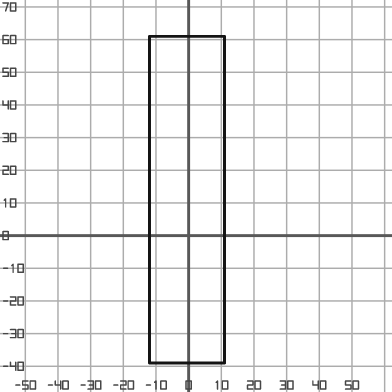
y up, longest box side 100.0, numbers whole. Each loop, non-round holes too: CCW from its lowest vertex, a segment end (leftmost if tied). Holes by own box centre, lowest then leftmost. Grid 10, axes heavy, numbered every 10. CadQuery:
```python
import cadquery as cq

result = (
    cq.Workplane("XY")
    .moveTo(-12.0, -39.0)
    .lineTo(11.0, -39.0)
    .lineTo(11.0, 61.0)
    .lineTo(-12.0, 61.0)
    .close()
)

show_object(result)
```